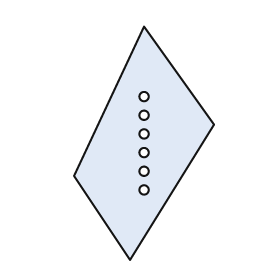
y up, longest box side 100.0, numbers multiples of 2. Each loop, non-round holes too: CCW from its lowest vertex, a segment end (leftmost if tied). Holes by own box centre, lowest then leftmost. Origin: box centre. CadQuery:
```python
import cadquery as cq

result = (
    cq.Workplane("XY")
    .moveTo(-6.0, -50.0)
    .lineTo(30.0, 8.0)
    .lineTo(0.0, 50.0)
    .lineTo(-30.0, -14.0)
    .close()
    .moveTo(0.0, -20.0)
    .circle(2.0)
    .moveTo(0.0, -12.0)
    .circle(2.0)
    .moveTo(0.0, -4.0)
    .circle(2.0)
    .moveTo(0.0, 4.0)
    .circle(2.0)
    .moveTo(0.0, 12.0)
    .circle(2.0)
    .moveTo(0.0, 20.0)
    .circle(2.0)
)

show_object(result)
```